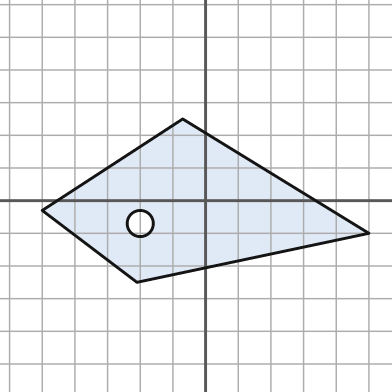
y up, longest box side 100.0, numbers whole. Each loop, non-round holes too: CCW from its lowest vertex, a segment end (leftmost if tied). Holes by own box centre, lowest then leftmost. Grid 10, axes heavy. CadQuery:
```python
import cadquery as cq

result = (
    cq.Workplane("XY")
    .moveTo(-21.0, -25.0)
    .lineTo(50.0, -10.0)
    .lineTo(-7.0, 25.0)
    .lineTo(-50.0, -3.0)
    .close()
    .moveTo(-20.0, -7.0)
    .circle(4.0)
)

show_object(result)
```